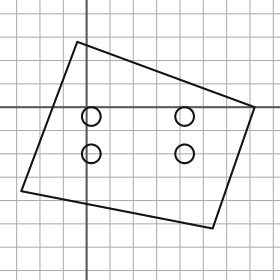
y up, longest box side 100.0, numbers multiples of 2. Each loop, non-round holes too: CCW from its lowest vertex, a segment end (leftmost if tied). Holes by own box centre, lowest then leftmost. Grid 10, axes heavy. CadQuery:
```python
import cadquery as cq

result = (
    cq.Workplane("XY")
    .moveTo(54.0, -52.0)
    .lineTo(72.0, 0.0)
    .lineTo(-4.0, 28.0)
    .lineTo(-28.0, -36.0)
    .close()
    .moveTo(2.0, -20.0)
    .circle(4.0)
    .moveTo(42.0, -20.0)
    .circle(4.0)
    .moveTo(2.0, -4.0)
    .circle(4.0)
    .moveTo(42.0, -4.0)
    .circle(4.0)
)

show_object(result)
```